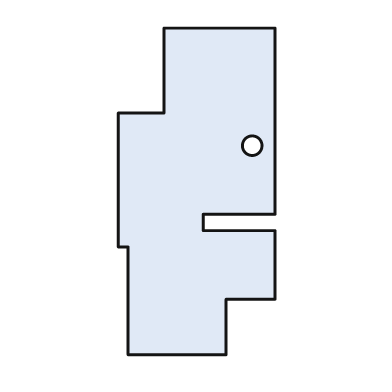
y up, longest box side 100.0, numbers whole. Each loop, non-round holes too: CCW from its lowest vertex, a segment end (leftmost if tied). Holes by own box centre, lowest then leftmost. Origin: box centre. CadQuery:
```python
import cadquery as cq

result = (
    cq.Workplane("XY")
    .moveTo(-21.0, -50.0)
    .lineTo(9.0, -50.0)
    .lineTo(9.0, -33.0)
    .lineTo(24.0, -33.0)
    .lineTo(24.0, -12.0)
    .lineTo(2.0, -12.0)
    .lineTo(2.0, -7.0)
    .lineTo(24.0, -7.0)
    .lineTo(24.0, 50.0)
    .lineTo(-10.0, 50.0)
    .lineTo(-10.0, 24.0)
    .lineTo(-24.0, 24.0)
    .lineTo(-24.0, -17.0)
    .lineTo(-21.0, -17.0)
    .close()
    .moveTo(17.0, 14.0)
    .circle(3.0)
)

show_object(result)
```